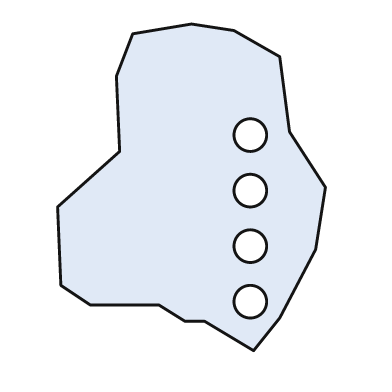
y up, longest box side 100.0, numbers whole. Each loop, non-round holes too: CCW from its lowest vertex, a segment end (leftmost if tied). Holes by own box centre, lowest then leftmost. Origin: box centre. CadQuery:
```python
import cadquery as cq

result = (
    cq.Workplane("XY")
    .moveTo(19.0, -50.0)
    .lineTo(27.0, -40.0)
    .lineTo(38.0, -19.0)
    .lineTo(41.0, 0.0)
    .lineTo(30.0, 17.0)
    .lineTo(27.0, 40.0)
    .lineTo(13.0, 48.0)
    .lineTo(0.0, 50.0)
    .lineTo(-18.0, 47.0)
    .lineTo(-23.0, 34.0)
    .lineTo(-22.0, 11.0)
    .lineTo(-41.0, -6.0)
    .lineTo(-40.0, -30.0)
    .lineTo(-31.0, -36.0)
    .lineTo(-10.0, -36.0)
    .lineTo(-2.0, -41.0)
    .lineTo(4.0, -41.0)
    .close()
    .moveTo(18.0, -35.0)
    .circle(5.0)
    .moveTo(18.0, -18.0)
    .circle(5.0)
    .moveTo(18.0, -1.0)
    .circle(5.0)
    .moveTo(18.0, 16.0)
    .circle(5.0)
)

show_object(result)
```